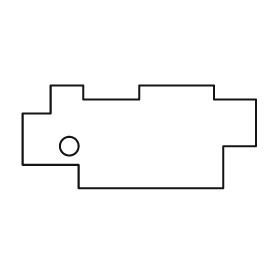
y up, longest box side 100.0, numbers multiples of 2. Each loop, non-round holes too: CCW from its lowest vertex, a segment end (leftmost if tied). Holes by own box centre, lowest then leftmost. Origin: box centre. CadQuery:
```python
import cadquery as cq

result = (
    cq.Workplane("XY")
    .moveTo(-26.0, -22.0)
    .lineTo(36.0, -22.0)
    .lineTo(36.0, -4.0)
    .lineTo(50.0, -4.0)
    .lineTo(50.0, 16.0)
    .lineTo(32.0, 16.0)
    .lineTo(32.0, 22.0)
    .lineTo(0.0, 22.0)
    .lineTo(0.0, 16.0)
    .lineTo(-24.0, 16.0)
    .lineTo(-24.0, 22.0)
    .lineTo(-38.0, 22.0)
    .lineTo(-38.0, 10.0)
    .lineTo(-50.0, 10.0)
    .lineTo(-50.0, -12.0)
    .lineTo(-26.0, -12.0)
    .close()
    .moveTo(-30.0, -4.0)
    .circle(4.0)
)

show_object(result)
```